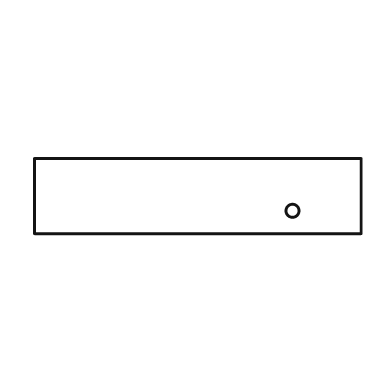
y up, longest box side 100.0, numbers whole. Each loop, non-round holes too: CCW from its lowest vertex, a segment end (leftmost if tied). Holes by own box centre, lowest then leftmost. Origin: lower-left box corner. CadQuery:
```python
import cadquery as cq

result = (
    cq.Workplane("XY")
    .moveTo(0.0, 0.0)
    .lineTo(100.0, 0.0)
    .lineTo(100.0, 23.0)
    .lineTo(0.0, 23.0)
    .close()
    .moveTo(79.0, 7.0)
    .circle(2.0)
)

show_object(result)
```